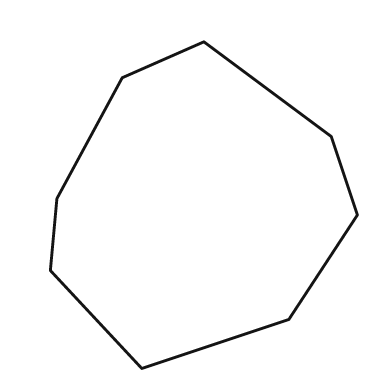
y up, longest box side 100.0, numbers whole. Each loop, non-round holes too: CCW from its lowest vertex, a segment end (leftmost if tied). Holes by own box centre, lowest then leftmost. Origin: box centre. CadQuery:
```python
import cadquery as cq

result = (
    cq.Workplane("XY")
    .moveTo(-19.0, -50.0)
    .lineTo(26.0, -35.0)
    .lineTo(47.0, -3.0)
    .lineTo(39.0, 21.0)
    .lineTo(0.0, 50.0)
    .lineTo(-25.0, 39.0)
    .lineTo(-45.0, 2.0)
    .lineTo(-47.0, -20.0)
    .close()
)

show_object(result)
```